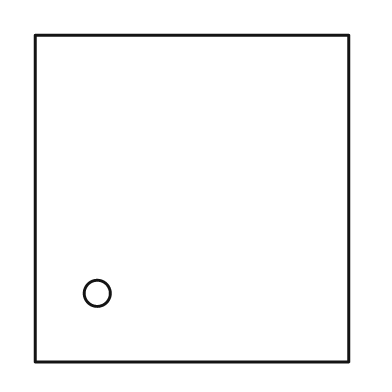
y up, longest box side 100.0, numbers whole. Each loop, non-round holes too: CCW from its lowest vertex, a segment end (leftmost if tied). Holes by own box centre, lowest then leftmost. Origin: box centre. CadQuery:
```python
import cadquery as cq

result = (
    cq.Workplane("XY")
    .moveTo(-48.0, -50.0)
    .lineTo(48.0, -50.0)
    .lineTo(48.0, 50.0)
    .lineTo(-48.0, 50.0)
    .close()
    .moveTo(-29.0, -29.0)
    .circle(4.0)
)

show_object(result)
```